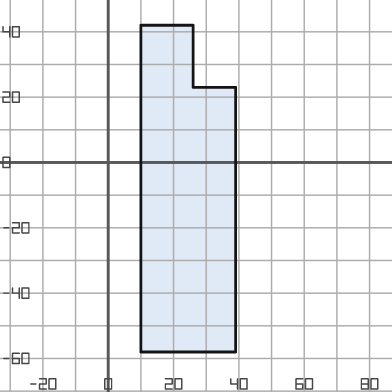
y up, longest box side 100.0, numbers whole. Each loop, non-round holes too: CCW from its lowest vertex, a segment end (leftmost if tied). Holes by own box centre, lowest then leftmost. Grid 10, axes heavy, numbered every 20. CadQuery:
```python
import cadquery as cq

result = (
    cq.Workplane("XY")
    .moveTo(10.0, -58.0)
    .lineTo(39.0, -58.0)
    .lineTo(39.0, 23.0)
    .lineTo(26.0, 23.0)
    .lineTo(26.0, 42.0)
    .lineTo(10.0, 42.0)
    .close()
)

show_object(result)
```